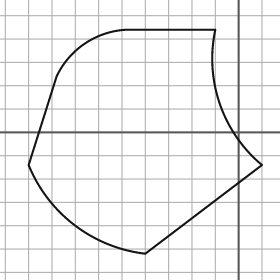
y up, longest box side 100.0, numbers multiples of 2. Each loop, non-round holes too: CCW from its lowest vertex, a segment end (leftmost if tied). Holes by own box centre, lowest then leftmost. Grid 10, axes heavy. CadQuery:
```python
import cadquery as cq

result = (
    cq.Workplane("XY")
    .moveTo(-40.0, -52.0)
    .lineTo(10.0, -14.0)
    .threePointArc((-8.0, 12.0), (-10.0, 44.0))
    .lineTo(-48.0, 44.0)
    .threePointArc((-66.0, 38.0), (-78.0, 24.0))
    .lineTo(-90.0, -14.0)
    .threePointArc((-70.0, -40.0), (-40.0, -52.0))
    .close()
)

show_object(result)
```